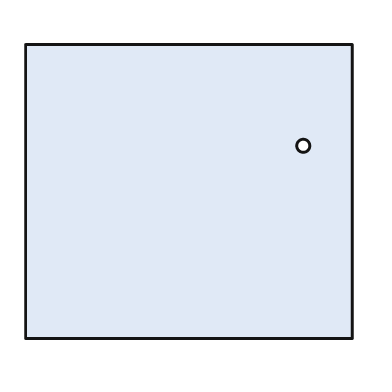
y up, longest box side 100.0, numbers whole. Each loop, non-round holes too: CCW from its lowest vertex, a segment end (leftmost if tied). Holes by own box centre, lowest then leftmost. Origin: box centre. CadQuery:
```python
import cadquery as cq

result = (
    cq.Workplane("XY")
    .moveTo(-50.0, -45.0)
    .lineTo(50.0, -45.0)
    .lineTo(50.0, 45.0)
    .lineTo(-50.0, 45.0)
    .close()
    .moveTo(35.0, 14.0)
    .circle(2.0)
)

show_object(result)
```